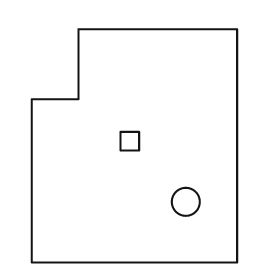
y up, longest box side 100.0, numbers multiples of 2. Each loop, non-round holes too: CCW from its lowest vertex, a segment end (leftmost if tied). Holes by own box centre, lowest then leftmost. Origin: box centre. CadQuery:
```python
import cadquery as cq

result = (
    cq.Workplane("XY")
    .moveTo(-44.0, -50.0)
    .lineTo(44.0, -50.0)
    .lineTo(44.0, 50.0)
    .lineTo(-24.0, 50.0)
    .lineTo(-24.0, 20.0)
    .lineTo(-44.0, 20.0)
    .close()
    .moveTo(22.0, -24.0)
    .circle(6.0)
    .moveTo(-6.0, -2.0)
    .lineTo(2.0, -2.0)
    .lineTo(2.0, 6.0)
    .lineTo(-6.0, 6.0)
    .close()
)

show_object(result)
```